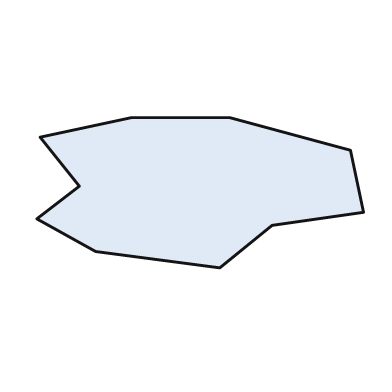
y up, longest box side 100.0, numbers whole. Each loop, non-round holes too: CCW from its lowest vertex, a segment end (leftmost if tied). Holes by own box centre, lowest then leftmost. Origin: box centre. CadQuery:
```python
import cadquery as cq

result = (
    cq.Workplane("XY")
    .moveTo(6.0, -23.0)
    .lineTo(22.0, -10.0)
    .lineTo(50.0, -6.0)
    .lineTo(46.0, 13.0)
    .lineTo(9.0, 23.0)
    .lineTo(-21.0, 23.0)
    .lineTo(-49.0, 17.0)
    .lineTo(-37.0, 2.0)
    .lineTo(-50.0, -8.0)
    .lineTo(-32.0, -18.0)
    .close()
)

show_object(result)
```